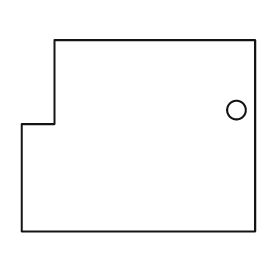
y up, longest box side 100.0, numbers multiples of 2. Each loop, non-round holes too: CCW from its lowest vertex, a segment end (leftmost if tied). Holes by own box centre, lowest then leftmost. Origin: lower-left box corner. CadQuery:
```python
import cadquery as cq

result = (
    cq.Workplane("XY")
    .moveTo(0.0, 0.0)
    .lineTo(100.0, 0.0)
    .lineTo(100.0, 82.0)
    .lineTo(14.0, 82.0)
    .lineTo(14.0, 46.0)
    .lineTo(0.0, 46.0)
    .close()
    .moveTo(92.0, 52.0)
    .circle(4.0)
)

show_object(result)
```